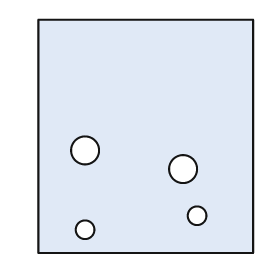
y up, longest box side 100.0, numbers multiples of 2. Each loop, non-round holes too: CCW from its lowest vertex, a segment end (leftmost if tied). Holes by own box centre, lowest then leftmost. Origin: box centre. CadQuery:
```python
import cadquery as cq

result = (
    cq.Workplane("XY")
    .moveTo(-46.0, -50.0)
    .lineTo(46.0, -50.0)
    .lineTo(46.0, 50.0)
    .lineTo(-46.0, 50.0)
    .close()
    .moveTo(-26.0, -40.0)
    .circle(4.0)
    .moveTo(22.0, -34.0)
    .circle(4.0)
    .moveTo(16.0, -14.0)
    .circle(6.0)
    .moveTo(-26.0, -6.0)
    .circle(6.0)
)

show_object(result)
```